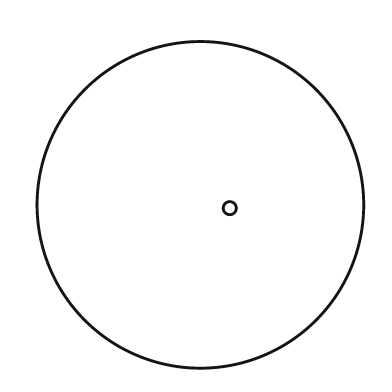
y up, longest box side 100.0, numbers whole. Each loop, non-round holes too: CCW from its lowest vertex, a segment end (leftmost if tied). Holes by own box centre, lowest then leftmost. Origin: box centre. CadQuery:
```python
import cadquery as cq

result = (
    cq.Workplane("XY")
    .moveTo(0.0, 0.0)
    .circle(50.0)
    .moveTo(9.0, -1.0)
    .circle(2.0)
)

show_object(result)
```